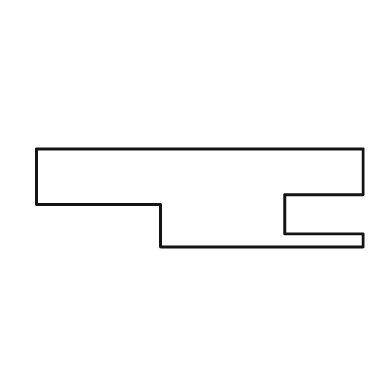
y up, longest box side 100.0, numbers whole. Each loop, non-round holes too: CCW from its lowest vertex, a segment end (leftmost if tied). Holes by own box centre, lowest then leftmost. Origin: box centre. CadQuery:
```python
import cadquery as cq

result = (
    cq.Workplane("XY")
    .moveTo(-12.0, -15.0)
    .lineTo(50.0, -15.0)
    .lineTo(50.0, -11.0)
    .lineTo(26.0, -11.0)
    .lineTo(26.0, 1.0)
    .lineTo(50.0, 1.0)
    .lineTo(50.0, 15.0)
    .lineTo(-50.0, 15.0)
    .lineTo(-50.0, -2.0)
    .lineTo(-12.0, -2.0)
    .close()
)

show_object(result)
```